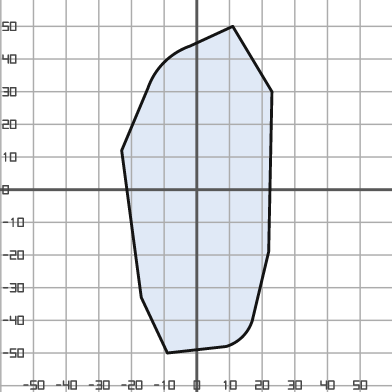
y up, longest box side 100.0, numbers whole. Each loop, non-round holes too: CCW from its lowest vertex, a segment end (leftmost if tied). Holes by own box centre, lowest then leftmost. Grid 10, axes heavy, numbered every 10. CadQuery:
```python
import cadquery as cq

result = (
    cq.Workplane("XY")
    .moveTo(-9.0, -50.0)
    .lineTo(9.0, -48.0)
    .threePointArc((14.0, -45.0), (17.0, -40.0))
    .lineTo(22.0, -19.0)
    .lineTo(23.0, 30.0)
    .lineTo(11.0, 50.0)
    .lineTo(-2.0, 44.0)
    .threePointArc((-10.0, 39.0), (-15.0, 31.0))
    .lineTo(-23.0, 12.0)
    .lineTo(-17.0, -33.0)
    .close()
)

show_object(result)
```